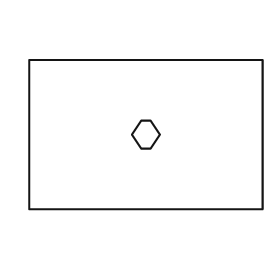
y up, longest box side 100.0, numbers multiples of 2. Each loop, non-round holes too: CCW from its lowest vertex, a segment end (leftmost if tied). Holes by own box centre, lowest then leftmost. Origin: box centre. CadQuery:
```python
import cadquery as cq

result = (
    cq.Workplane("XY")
    .moveTo(-50.0, -32.0)
    .lineTo(50.0, -32.0)
    .lineTo(50.0, 32.0)
    .lineTo(-50.0, 32.0)
    .close()
    .moveTo(-2.0, -6.0)
    .lineTo(2.0, -6.0)
    .lineTo(6.0, 0.0)
    .lineTo(2.0, 6.0)
    .lineTo(-2.0, 6.0)
    .lineTo(-6.0, 0.0)
    .close()
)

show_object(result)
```